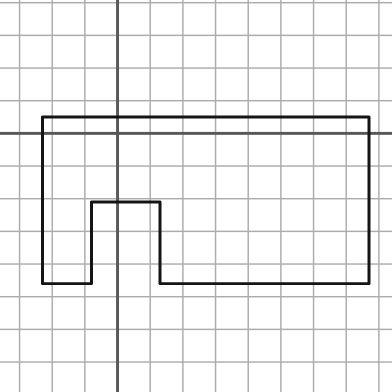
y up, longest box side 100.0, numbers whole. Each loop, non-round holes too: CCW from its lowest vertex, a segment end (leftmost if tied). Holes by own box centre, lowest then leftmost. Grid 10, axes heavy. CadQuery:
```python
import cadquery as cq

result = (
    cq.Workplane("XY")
    .moveTo(-23.0, -46.0)
    .lineTo(-8.0, -46.0)
    .lineTo(-8.0, -21.0)
    .lineTo(13.0, -21.0)
    .lineTo(13.0, -46.0)
    .lineTo(77.0, -46.0)
    .lineTo(77.0, 5.0)
    .lineTo(-23.0, 5.0)
    .close()
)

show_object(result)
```